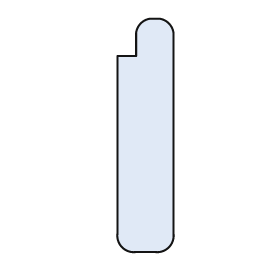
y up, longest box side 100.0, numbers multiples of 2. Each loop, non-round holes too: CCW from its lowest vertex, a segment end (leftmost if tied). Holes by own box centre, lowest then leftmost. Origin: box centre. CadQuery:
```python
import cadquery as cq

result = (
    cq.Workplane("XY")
    .moveTo(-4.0, -50.0)
    .lineTo(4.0, -50.0)
    .threePointArc((10.0, -48.0), (12.0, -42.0))
    .lineTo(12.0, 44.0)
    .threePointArc((10.0, 48.0), (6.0, 50.0))
    .lineTo(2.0, 50.0)
    .threePointArc((-2.0, 48.0), (-4.0, 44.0))
    .lineTo(-4.0, 34.0)
    .lineTo(-12.0, 34.0)
    .lineTo(-12.0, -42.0)
    .threePointArc((-10.0, -48.0), (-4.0, -50.0))
    .close()
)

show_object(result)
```